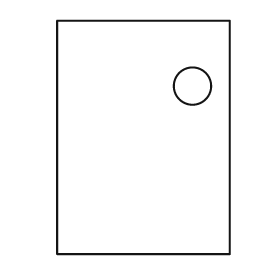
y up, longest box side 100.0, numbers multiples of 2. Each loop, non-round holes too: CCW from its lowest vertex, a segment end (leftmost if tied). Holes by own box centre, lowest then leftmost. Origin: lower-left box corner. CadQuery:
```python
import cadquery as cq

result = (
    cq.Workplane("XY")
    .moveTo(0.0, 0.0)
    .lineTo(74.0, 0.0)
    .lineTo(74.0, 100.0)
    .lineTo(0.0, 100.0)
    .close()
    .moveTo(58.0, 72.0)
    .circle(8.0)
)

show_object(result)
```